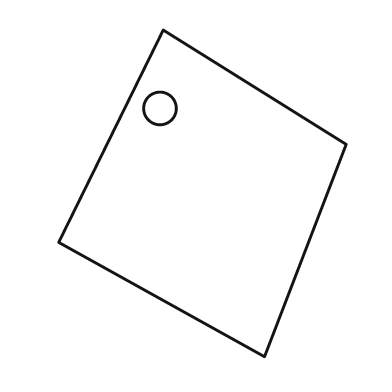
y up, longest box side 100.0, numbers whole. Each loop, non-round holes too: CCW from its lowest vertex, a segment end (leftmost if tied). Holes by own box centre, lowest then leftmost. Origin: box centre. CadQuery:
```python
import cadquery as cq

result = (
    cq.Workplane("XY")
    .moveTo(19.0, -50.0)
    .lineTo(44.0, 15.0)
    .lineTo(-12.0, 50.0)
    .lineTo(-44.0, -15.0)
    .close()
    .moveTo(-13.0, 26.0)
    .circle(5.0)
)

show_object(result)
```